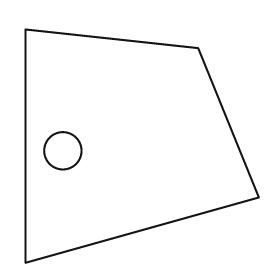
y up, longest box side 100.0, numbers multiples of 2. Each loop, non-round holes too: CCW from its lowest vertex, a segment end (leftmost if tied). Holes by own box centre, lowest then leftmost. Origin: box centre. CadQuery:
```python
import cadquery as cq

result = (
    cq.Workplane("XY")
    .moveTo(-50.0, -50.0)
    .lineTo(50.0, -22.0)
    .lineTo(24.0, 42.0)
    .lineTo(-50.0, 50.0)
    .close()
    .moveTo(-34.0, -2.0)
    .circle(8.0)
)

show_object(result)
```